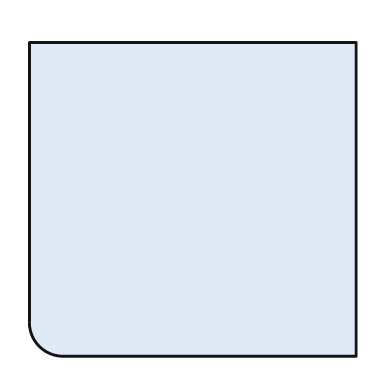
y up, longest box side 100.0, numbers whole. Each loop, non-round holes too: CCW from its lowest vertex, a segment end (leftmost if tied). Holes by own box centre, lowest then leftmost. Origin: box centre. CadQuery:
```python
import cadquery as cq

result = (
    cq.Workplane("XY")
    .moveTo(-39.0, -48.0)
    .lineTo(50.0, -48.0)
    .lineTo(50.0, 48.0)
    .lineTo(-50.0, 48.0)
    .lineTo(-50.0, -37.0)
    .threePointArc((-47.0, -45.0), (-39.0, -48.0))
    .close()
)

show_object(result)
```